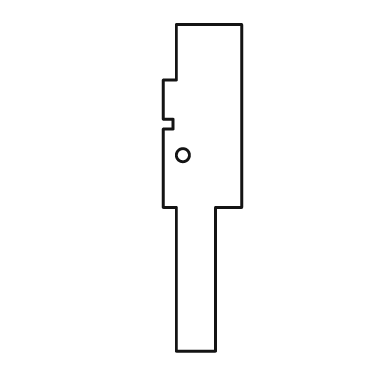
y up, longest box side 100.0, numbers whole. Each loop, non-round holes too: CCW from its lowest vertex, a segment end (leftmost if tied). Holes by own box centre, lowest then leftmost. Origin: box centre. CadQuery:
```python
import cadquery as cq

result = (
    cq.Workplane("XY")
    .moveTo(-8.0, -50.0)
    .lineTo(4.0, -50.0)
    .lineTo(4.0, -6.0)
    .lineTo(12.0, -6.0)
    .lineTo(12.0, 50.0)
    .lineTo(-8.0, 50.0)
    .lineTo(-8.0, 33.0)
    .lineTo(-12.0, 33.0)
    .lineTo(-12.0, 21.0)
    .lineTo(-9.0, 21.0)
    .lineTo(-9.0, 18.0)
    .lineTo(-12.0, 18.0)
    .lineTo(-12.0, -6.0)
    .lineTo(-8.0, -6.0)
    .close()
    .moveTo(-6.0, 10.0)
    .circle(2.0)
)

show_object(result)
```